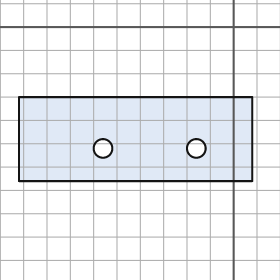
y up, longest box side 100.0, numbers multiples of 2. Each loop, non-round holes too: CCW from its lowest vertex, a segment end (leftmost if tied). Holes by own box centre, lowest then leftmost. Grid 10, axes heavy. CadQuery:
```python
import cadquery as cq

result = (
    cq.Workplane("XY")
    .moveTo(-92.0, -66.0)
    .lineTo(8.0, -66.0)
    .lineTo(8.0, -30.0)
    .lineTo(-92.0, -30.0)
    .close()
    .moveTo(-56.0, -52.0)
    .circle(4.0)
    .moveTo(-16.0, -52.0)
    .circle(4.0)
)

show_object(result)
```